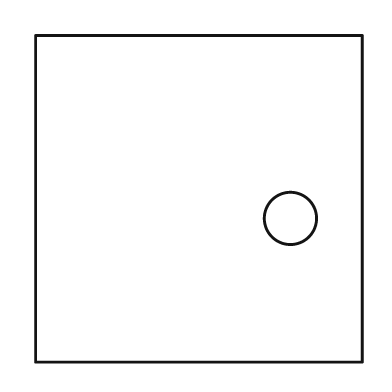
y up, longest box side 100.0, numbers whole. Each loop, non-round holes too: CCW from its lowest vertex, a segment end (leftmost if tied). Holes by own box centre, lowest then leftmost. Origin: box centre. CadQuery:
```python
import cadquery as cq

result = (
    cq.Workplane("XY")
    .moveTo(-50.0, -50.0)
    .lineTo(50.0, -50.0)
    .lineTo(50.0, 50.0)
    .lineTo(-50.0, 50.0)
    .close()
    .moveTo(28.0, -6.0)
    .circle(8.0)
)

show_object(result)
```